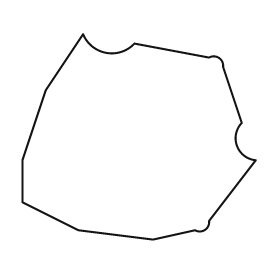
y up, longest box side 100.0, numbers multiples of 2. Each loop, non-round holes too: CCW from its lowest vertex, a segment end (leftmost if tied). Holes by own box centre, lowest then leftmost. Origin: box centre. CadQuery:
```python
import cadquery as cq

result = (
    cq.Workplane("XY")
    .moveTo(6.0, -44.0)
    .lineTo(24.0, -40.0)
    .threePointArc((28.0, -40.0), (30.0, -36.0))
    .lineTo(50.0, -10.0)
    .threePointArc((42.0, -4.0), (44.0, 6.0))
    .lineTo(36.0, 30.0)
    .threePointArc((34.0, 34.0), (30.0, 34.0))
    .lineTo(-2.0, 40.0)
    .threePointArc((-14.0, 36.0), (-24.0, 44.0))
    .lineTo(-40.0, 20.0)
    .lineTo(-50.0, -10.0)
    .lineTo(-50.0, -28.0)
    .lineTo(-26.0, -40.0)
    .close()
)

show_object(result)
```